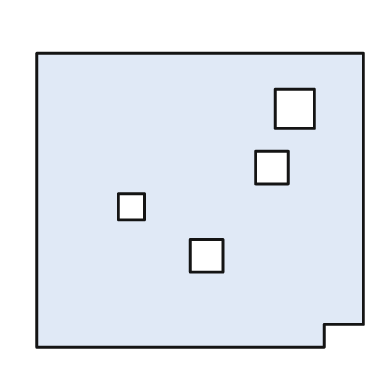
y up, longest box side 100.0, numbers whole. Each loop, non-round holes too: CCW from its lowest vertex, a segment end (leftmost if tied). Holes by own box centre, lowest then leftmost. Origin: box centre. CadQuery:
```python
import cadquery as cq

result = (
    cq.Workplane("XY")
    .moveTo(-50.0, -45.0)
    .lineTo(38.0, -45.0)
    .lineTo(38.0, -38.0)
    .lineTo(50.0, -38.0)
    .lineTo(50.0, 45.0)
    .lineTo(-50.0, 45.0)
    .close()
    .moveTo(-3.0, -22.0)
    .lineTo(7.0, -22.0)
    .lineTo(7.0, -12.0)
    .lineTo(-3.0, -12.0)
    .close()
    .moveTo(-25.0, -6.0)
    .lineTo(-17.0, -6.0)
    .lineTo(-17.0, 2.0)
    .lineTo(-25.0, 2.0)
    .close()
    .moveTo(17.0, 5.0)
    .lineTo(27.0, 5.0)
    .lineTo(27.0, 15.0)
    .lineTo(17.0, 15.0)
    .close()
    .moveTo(23.0, 22.0)
    .lineTo(35.0, 22.0)
    .lineTo(35.0, 34.0)
    .lineTo(23.0, 34.0)
    .close()
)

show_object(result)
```